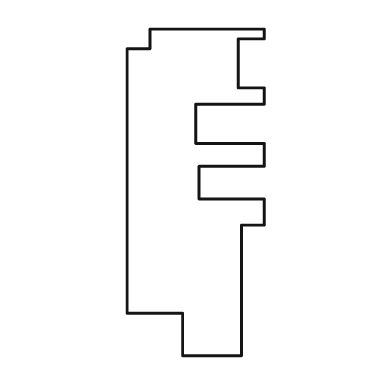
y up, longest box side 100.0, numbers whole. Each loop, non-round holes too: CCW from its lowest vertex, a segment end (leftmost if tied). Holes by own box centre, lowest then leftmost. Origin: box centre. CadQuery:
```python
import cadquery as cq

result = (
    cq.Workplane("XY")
    .moveTo(-4.0, -50.0)
    .lineTo(14.0, -50.0)
    .lineTo(14.0, -10.0)
    .lineTo(21.0, -10.0)
    .lineTo(21.0, -2.0)
    .lineTo(1.0, -2.0)
    .lineTo(1.0, 8.0)
    .lineTo(21.0, 8.0)
    .lineTo(21.0, 15.0)
    .lineTo(0.0, 15.0)
    .lineTo(0.0, 27.0)
    .lineTo(21.0, 27.0)
    .lineTo(21.0, 32.0)
    .lineTo(13.0, 32.0)
    .lineTo(13.0, 47.0)
    .lineTo(21.0, 47.0)
    .lineTo(21.0, 50.0)
    .lineTo(-14.0, 50.0)
    .lineTo(-14.0, 44.0)
    .lineTo(-21.0, 44.0)
    .lineTo(-21.0, -37.0)
    .lineTo(-4.0, -37.0)
    .close()
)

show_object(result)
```